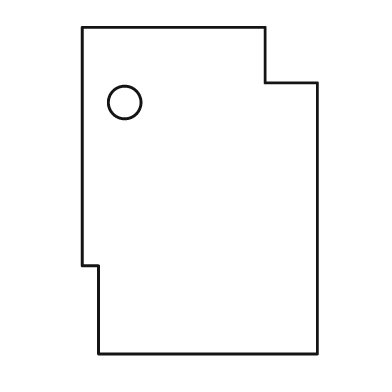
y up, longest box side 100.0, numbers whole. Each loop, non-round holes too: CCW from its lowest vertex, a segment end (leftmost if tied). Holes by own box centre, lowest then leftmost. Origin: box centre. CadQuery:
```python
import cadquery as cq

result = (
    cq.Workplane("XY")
    .moveTo(-31.0, -50.0)
    .lineTo(36.0, -50.0)
    .lineTo(36.0, 33.0)
    .lineTo(20.0, 33.0)
    .lineTo(20.0, 50.0)
    .lineTo(-36.0, 50.0)
    .lineTo(-36.0, -23.0)
    .lineTo(-31.0, -23.0)
    .close()
    .moveTo(-23.0, 27.0)
    .circle(5.0)
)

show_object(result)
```